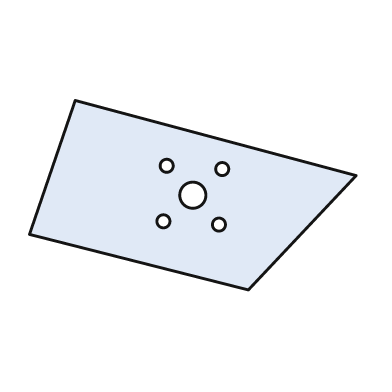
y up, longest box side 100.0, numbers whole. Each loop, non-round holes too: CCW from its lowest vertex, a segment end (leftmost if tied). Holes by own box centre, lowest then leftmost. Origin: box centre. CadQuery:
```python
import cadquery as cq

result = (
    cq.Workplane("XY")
    .moveTo(17.0, -29.0)
    .lineTo(50.0, 6.0)
    .lineTo(-36.0, 29.0)
    .lineTo(-50.0, -12.0)
    .close()
    .moveTo(8.0, -9.0)
    .circle(2.0)
    .moveTo(-9.0, -8.0)
    .circle(2.0)
    .moveTo(0.0, 0.0)
    .circle(4.0)
    .moveTo(9.0, 8.0)
    .circle(2.0)
    .moveTo(-8.0, 9.0)
    .circle(2.0)
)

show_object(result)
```